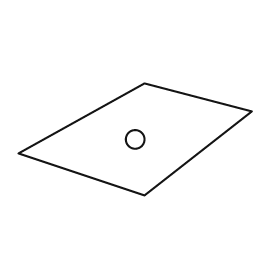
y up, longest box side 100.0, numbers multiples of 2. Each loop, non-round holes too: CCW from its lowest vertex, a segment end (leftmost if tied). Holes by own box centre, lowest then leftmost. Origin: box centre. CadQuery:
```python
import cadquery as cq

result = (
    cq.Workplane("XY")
    .moveTo(4.0, -24.0)
    .lineTo(50.0, 12.0)
    .lineTo(4.0, 24.0)
    .lineTo(-50.0, -6.0)
    .close()
    .moveTo(0.0, 0.0)
    .circle(4.0)
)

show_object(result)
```